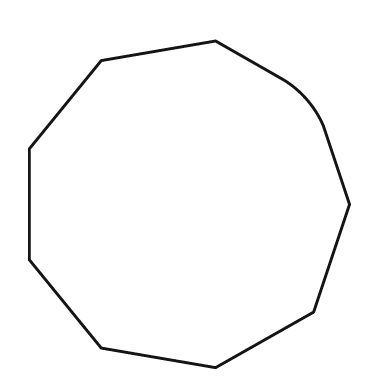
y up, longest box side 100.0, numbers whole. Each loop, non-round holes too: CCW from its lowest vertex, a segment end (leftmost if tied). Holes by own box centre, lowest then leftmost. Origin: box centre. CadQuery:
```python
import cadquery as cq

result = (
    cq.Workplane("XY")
    .moveTo(8.0, -50.0)
    .lineTo(38.0, -33.0)
    .lineTo(49.0, 0.0)
    .lineTo(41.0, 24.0)
    .threePointArc((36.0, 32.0), (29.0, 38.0))
    .lineTo(8.0, 50.0)
    .lineTo(-27.0, 44.0)
    .lineTo(-49.0, 17.0)
    .lineTo(-49.0, -17.0)
    .lineTo(-27.0, -44.0)
    .close()
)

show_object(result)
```